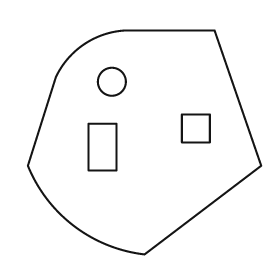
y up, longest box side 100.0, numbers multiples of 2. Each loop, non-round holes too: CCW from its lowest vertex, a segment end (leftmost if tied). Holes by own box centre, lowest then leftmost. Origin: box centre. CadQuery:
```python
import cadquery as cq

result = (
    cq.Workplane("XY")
    .moveTo(0.0, -48.0)
    .lineTo(50.0, -10.0)
    .lineTo(30.0, 48.0)
    .lineTo(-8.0, 48.0)
    .threePointArc((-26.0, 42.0), (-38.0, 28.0))
    .lineTo(-50.0, -10.0)
    .threePointArc((-30.0, -36.0), (0.0, -48.0))
    .close()
    .moveTo(-24.0, -12.0)
    .lineTo(-12.0, -12.0)
    .lineTo(-12.0, 8.0)
    .lineTo(-24.0, 8.0)
    .close()
    .moveTo(16.0, 0.0)
    .lineTo(28.0, 0.0)
    .lineTo(28.0, 12.0)
    .lineTo(16.0, 12.0)
    .close()
    .moveTo(-14.0, 26.0)
    .circle(6.0)
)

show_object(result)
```